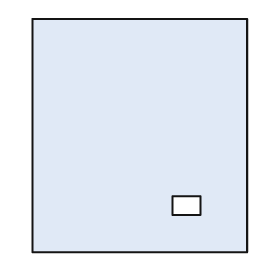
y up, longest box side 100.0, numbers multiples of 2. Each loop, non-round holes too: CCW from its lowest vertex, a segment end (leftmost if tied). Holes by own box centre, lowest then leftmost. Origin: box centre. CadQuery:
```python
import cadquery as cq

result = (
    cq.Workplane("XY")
    .moveTo(-46.0, -50.0)
    .lineTo(46.0, -50.0)
    .lineTo(46.0, 50.0)
    .lineTo(-46.0, 50.0)
    .close()
    .moveTo(14.0, -34.0)
    .lineTo(26.0, -34.0)
    .lineTo(26.0, -26.0)
    .lineTo(14.0, -26.0)
    .close()
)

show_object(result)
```